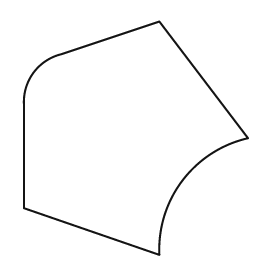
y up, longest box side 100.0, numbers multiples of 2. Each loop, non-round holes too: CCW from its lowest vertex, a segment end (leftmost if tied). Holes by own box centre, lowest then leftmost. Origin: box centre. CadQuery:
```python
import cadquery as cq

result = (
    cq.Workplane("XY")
    .moveTo(10.0, -50.0)
    .threePointArc((20.0, -18.0), (48.0, 0.0))
    .lineTo(10.0, 50.0)
    .lineTo(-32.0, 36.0)
    .threePointArc((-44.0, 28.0), (-48.0, 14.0))
    .lineTo(-48.0, -30.0)
    .close()
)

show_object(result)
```